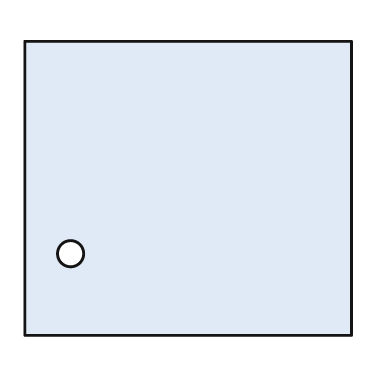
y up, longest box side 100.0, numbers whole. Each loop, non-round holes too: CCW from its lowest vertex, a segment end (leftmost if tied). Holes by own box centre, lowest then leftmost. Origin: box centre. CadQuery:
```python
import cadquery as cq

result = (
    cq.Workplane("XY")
    .moveTo(-50.0, -45.0)
    .lineTo(50.0, -45.0)
    .lineTo(50.0, 45.0)
    .lineTo(-50.0, 45.0)
    .close()
    .moveTo(-36.0, -20.0)
    .circle(4.0)
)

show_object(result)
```